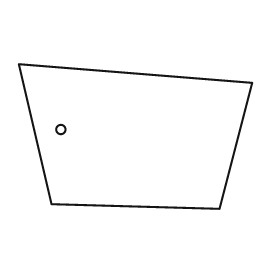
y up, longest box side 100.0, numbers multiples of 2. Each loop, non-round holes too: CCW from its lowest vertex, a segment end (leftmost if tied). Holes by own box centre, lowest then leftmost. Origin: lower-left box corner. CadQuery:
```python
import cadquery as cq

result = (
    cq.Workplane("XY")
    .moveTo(86.0, 0.0)
    .lineTo(100.0, 54.0)
    .lineTo(0.0, 62.0)
    .lineTo(14.0, 2.0)
    .close()
    .moveTo(18.0, 34.0)
    .circle(2.0)
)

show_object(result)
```